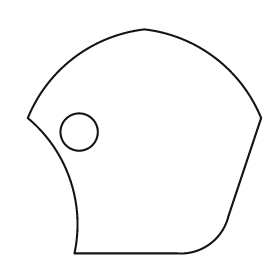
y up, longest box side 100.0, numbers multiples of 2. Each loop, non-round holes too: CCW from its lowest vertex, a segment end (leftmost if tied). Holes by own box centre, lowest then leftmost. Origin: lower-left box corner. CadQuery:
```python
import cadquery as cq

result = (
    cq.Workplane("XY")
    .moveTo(20.0, 0.0)
    .lineTo(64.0, 0.0)
    .threePointArc((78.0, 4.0), (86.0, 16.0))
    .lineTo(100.0, 58.0)
    .threePointArc((80.0, 84.0), (50.0, 96.0))
    .threePointArc((20.0, 84.0), (0.0, 58.0))
    .threePointArc((18.0, 32.0), (20.0, 0.0))
    .close()
    .moveTo(22.0, 52.0)
    .circle(8.0)
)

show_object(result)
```